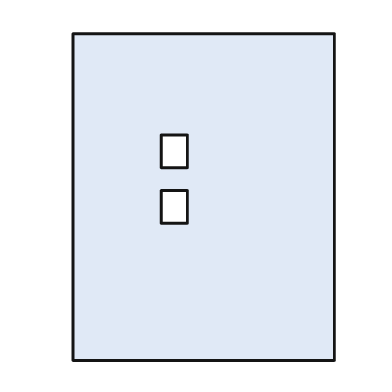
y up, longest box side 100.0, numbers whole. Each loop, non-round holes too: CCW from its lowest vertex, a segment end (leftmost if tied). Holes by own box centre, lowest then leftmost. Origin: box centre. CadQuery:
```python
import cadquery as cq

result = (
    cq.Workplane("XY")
    .moveTo(-40.0, -50.0)
    .lineTo(40.0, -50.0)
    .lineTo(40.0, 50.0)
    .lineTo(-40.0, 50.0)
    .close()
    .moveTo(-13.0, -8.0)
    .lineTo(-5.0, -8.0)
    .lineTo(-5.0, 2.0)
    .lineTo(-13.0, 2.0)
    .close()
    .moveTo(-13.0, 9.0)
    .lineTo(-5.0, 9.0)
    .lineTo(-5.0, 19.0)
    .lineTo(-13.0, 19.0)
    .close()
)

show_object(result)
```